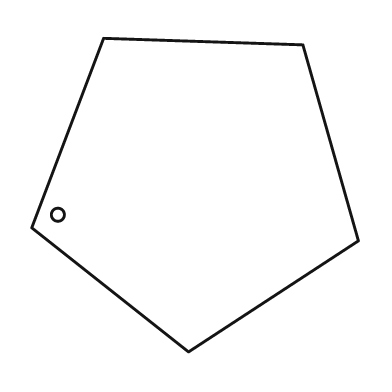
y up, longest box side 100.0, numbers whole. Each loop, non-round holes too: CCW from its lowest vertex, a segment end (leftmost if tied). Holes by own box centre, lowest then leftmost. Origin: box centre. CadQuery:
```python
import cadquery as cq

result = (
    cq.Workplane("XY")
    .moveTo(-2.0, -48.0)
    .lineTo(50.0, -14.0)
    .lineTo(33.0, 46.0)
    .lineTo(-28.0, 48.0)
    .lineTo(-50.0, -10.0)
    .close()
    .moveTo(-42.0, -6.0)
    .circle(2.0)
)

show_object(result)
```